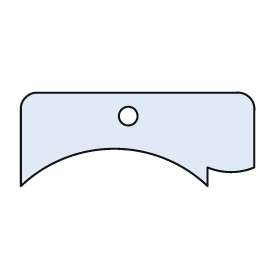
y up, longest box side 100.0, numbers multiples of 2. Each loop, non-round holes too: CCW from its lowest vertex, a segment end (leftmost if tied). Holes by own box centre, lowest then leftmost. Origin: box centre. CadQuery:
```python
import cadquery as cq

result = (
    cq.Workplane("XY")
    .moveTo(-50.0, -20.0)
    .threePointArc((-10.0, -4.0), (30.0, -20.0))
    .lineTo(30.0, -12.0)
    .threePointArc((40.0, -14.0), (50.0, -12.0))
    .lineTo(50.0, 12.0)
    .threePointArc((48.0, 18.0), (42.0, 20.0))
    .lineTo(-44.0, 20.0)
    .threePointArc((-48.0, 18.0), (-50.0, 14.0))
    .close()
    .moveTo(-4.0, 10.0)
    .circle(4.0)
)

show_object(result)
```